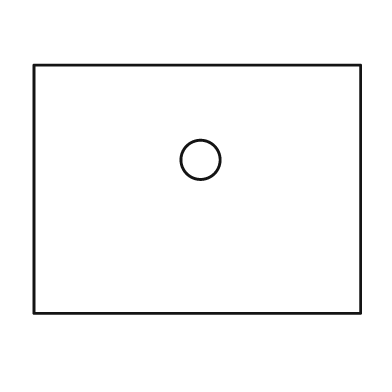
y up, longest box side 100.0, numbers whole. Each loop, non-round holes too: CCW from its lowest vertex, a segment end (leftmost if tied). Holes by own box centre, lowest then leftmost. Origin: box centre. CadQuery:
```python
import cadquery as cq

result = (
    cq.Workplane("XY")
    .moveTo(-50.0, -38.0)
    .lineTo(50.0, -38.0)
    .lineTo(50.0, 38.0)
    .lineTo(-50.0, 38.0)
    .close()
    .moveTo(1.0, 9.0)
    .circle(6.0)
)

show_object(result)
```